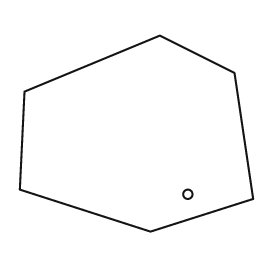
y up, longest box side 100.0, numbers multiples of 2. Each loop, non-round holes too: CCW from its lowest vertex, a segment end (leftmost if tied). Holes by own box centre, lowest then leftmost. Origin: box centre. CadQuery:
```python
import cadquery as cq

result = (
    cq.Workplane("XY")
    .moveTo(6.0, -42.0)
    .lineTo(50.0, -28.0)
    .lineTo(42.0, 26.0)
    .lineTo(10.0, 42.0)
    .lineTo(-48.0, 18.0)
    .lineTo(-50.0, -24.0)
    .close()
    .moveTo(22.0, -26.0)
    .circle(2.0)
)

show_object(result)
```